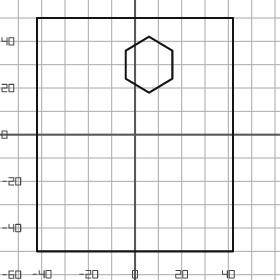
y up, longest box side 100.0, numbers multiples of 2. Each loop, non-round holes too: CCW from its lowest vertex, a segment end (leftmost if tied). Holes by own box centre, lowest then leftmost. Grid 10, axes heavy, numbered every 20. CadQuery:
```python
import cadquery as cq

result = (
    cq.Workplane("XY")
    .moveTo(-42.0, -50.0)
    .lineTo(42.0, -50.0)
    .lineTo(42.0, 50.0)
    .lineTo(-42.0, 50.0)
    .close()
    .moveTo(6.0, 18.0)
    .lineTo(16.0, 24.0)
    .lineTo(16.0, 36.0)
    .lineTo(6.0, 42.0)
    .lineTo(-4.0, 36.0)
    .lineTo(-4.0, 24.0)
    .close()
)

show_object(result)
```